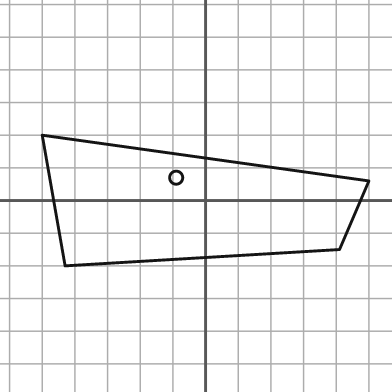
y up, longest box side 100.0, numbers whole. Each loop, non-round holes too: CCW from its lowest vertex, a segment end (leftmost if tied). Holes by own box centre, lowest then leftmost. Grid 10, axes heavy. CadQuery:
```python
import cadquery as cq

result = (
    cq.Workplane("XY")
    .moveTo(-43.0, -20.0)
    .lineTo(41.0, -15.0)
    .lineTo(50.0, 6.0)
    .lineTo(-50.0, 20.0)
    .close()
    .moveTo(-9.0, 7.0)
    .circle(2.0)
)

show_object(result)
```